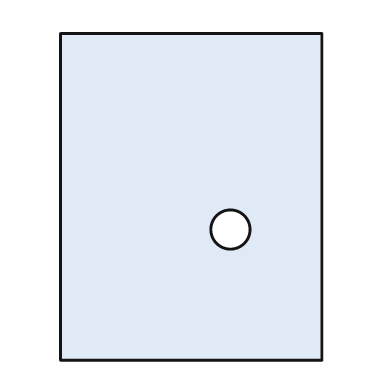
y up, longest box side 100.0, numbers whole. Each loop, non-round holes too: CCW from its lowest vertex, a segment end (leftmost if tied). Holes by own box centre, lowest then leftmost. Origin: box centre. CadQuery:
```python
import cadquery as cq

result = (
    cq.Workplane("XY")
    .moveTo(-40.0, -50.0)
    .lineTo(40.0, -50.0)
    .lineTo(40.0, 50.0)
    .lineTo(-40.0, 50.0)
    .close()
    .moveTo(12.0, -10.0)
    .circle(6.0)
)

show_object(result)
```